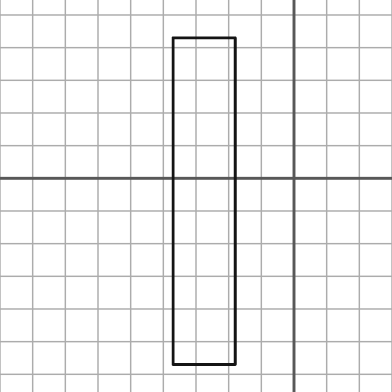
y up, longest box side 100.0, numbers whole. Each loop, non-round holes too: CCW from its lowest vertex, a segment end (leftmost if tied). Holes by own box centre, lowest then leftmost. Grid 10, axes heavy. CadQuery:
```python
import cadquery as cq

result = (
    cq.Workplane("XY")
    .moveTo(-37.0, -57.0)
    .lineTo(-18.0, -57.0)
    .lineTo(-18.0, 43.0)
    .lineTo(-37.0, 43.0)
    .close()
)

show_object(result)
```